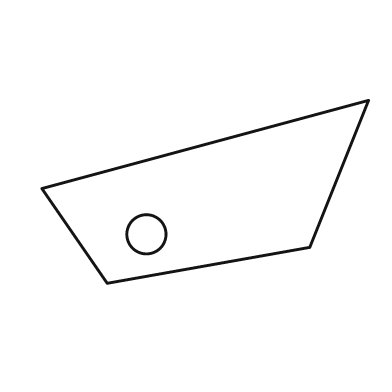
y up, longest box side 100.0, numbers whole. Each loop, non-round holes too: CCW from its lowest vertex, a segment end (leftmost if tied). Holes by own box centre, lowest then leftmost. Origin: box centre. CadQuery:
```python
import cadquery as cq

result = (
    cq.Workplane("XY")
    .moveTo(-30.0, -28.0)
    .lineTo(32.0, -17.0)
    .lineTo(50.0, 28.0)
    .lineTo(-50.0, 1.0)
    .close()
    .moveTo(-18.0, -13.0)
    .circle(6.0)
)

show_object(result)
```